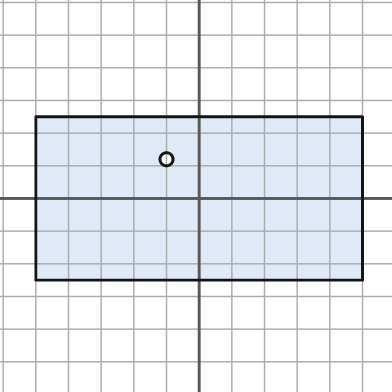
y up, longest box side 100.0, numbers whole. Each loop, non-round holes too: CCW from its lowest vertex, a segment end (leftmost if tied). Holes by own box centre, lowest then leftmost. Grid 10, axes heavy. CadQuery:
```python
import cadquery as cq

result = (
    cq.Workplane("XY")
    .moveTo(-50.0, -25.0)
    .lineTo(50.0, -25.0)
    .lineTo(50.0, 25.0)
    .lineTo(-50.0, 25.0)
    .close()
    .moveTo(-10.0, 12.0)
    .circle(2.0)
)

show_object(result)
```